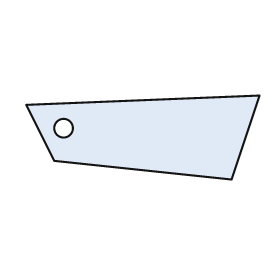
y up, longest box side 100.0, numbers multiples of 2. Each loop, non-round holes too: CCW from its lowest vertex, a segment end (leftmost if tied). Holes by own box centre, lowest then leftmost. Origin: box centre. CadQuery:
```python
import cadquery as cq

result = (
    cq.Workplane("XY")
    .moveTo(38.0, -18.0)
    .lineTo(50.0, 18.0)
    .lineTo(-50.0, 14.0)
    .lineTo(-38.0, -10.0)
    .close()
    .moveTo(-34.0, 4.0)
    .circle(4.0)
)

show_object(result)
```